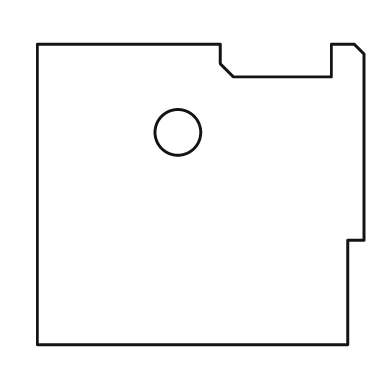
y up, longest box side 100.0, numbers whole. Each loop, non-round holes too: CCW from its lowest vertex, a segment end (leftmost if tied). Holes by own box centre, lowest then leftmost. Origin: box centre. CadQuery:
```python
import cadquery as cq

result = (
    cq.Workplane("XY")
    .moveTo(-50.0, -46.0)
    .lineTo(45.0, -46.0)
    .lineTo(45.0, -14.0)
    .lineTo(50.0, -14.0)
    .lineTo(50.0, 43.0)
    .lineTo(47.0, 46.0)
    .lineTo(40.0, 46.0)
    .lineTo(40.0, 36.0)
    .lineTo(10.0, 36.0)
    .lineTo(6.0, 40.0)
    .lineTo(6.0, 46.0)
    .lineTo(-50.0, 46.0)
    .close()
    .moveTo(-7.0, 19.0)
    .circle(7.0)
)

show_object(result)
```